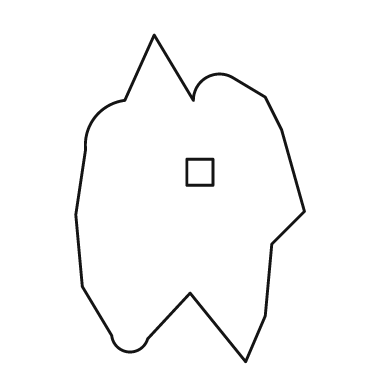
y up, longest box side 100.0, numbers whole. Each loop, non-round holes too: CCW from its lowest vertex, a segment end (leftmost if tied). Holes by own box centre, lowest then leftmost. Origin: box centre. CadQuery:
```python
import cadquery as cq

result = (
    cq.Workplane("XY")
    .moveTo(17.0, -50.0)
    .lineTo(23.0, -36.0)
    .lineTo(25.0, -14.0)
    .lineTo(35.0, -4.0)
    .lineTo(28.0, 21.0)
    .lineTo(23.0, 31.0)
    .lineTo(13.0, 37.0)
    .threePointArc((5.0, 37.0), (1.0, 30.0))
    .lineTo(-11.0, 50.0)
    .lineTo(-20.0, 30.0)
    .threePointArc((-29.0, 25.0), (-32.0, 15.0))
    .lineTo(-35.0, -5.0)
    .lineTo(-33.0, -27.0)
    .lineTo(-24.0, -42.0)
    .threePointArc((-19.0, -47.0), (-13.0, -43.0))
    .lineTo(0.0, -29.0)
    .close()
    .moveTo(-1.0, 4.0)
    .lineTo(7.0, 4.0)
    .lineTo(7.0, 12.0)
    .lineTo(-1.0, 12.0)
    .close()
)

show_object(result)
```